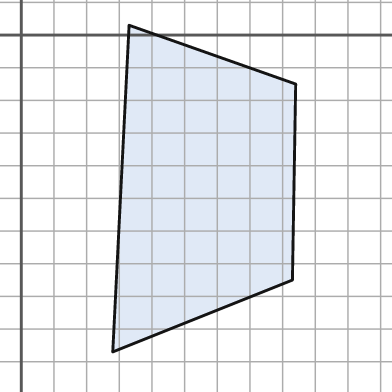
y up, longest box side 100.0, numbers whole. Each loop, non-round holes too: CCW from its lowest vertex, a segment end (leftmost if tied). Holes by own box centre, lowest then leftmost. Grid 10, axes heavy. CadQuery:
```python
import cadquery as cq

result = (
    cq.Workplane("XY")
    .moveTo(28.0, -97.0)
    .lineTo(83.0, -75.0)
    .lineTo(84.0, -15.0)
    .lineTo(33.0, 3.0)
    .close()
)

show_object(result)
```